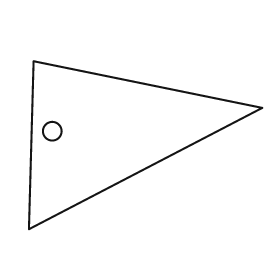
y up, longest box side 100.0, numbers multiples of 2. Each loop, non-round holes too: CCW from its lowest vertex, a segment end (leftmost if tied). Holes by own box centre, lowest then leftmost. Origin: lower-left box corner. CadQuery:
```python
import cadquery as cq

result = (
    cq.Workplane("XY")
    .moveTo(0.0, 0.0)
    .lineTo(100.0, 52.0)
    .lineTo(2.0, 72.0)
    .close()
    .moveTo(10.0, 42.0)
    .circle(4.0)
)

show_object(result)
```